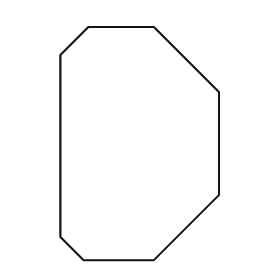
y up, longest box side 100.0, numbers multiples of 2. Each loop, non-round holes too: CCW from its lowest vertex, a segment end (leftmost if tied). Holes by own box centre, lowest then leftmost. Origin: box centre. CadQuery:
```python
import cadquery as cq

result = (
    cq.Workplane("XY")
    .moveTo(-24.0, -50.0)
    .lineTo(6.0, -50.0)
    .lineTo(34.0, -22.0)
    .lineTo(34.0, 22.0)
    .lineTo(6.0, 50.0)
    .lineTo(-22.0, 50.0)
    .lineTo(-34.0, 38.0)
    .lineTo(-34.0, -40.0)
    .close()
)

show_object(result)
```